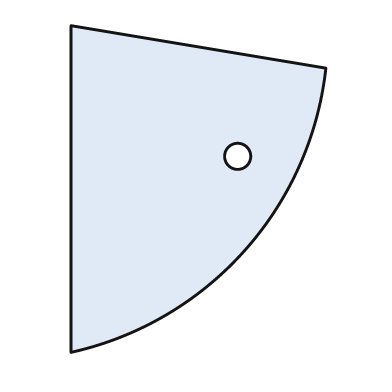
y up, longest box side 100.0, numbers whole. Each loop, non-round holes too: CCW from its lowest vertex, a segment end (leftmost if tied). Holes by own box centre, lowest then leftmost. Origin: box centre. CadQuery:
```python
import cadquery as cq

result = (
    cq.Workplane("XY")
    .moveTo(-39.0, -50.0)
    .threePointArc((14.0, -19.0), (39.0, 37.0))
    .lineTo(-39.0, 50.0)
    .close()
    .moveTo(12.0, 10.0)
    .circle(4.0)
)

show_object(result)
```